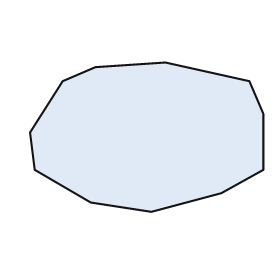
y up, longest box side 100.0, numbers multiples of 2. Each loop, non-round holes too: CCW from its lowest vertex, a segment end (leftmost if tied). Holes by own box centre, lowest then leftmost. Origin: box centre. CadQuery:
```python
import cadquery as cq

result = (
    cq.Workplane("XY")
    .moveTo(2.0, -32.0)
    .lineTo(32.0, -24.0)
    .lineTo(50.0, -14.0)
    .lineTo(50.0, 10.0)
    .lineTo(44.0, 24.0)
    .lineTo(8.0, 32.0)
    .lineTo(-22.0, 30.0)
    .lineTo(-36.0, 24.0)
    .lineTo(-50.0, 2.0)
    .lineTo(-48.0, -14.0)
    .lineTo(-24.0, -28.0)
    .close()
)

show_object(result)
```